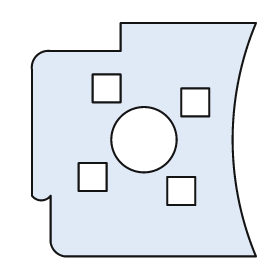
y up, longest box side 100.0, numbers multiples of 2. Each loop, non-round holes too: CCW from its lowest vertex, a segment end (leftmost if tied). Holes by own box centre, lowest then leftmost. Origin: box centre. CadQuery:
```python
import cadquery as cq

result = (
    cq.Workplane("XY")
    .moveTo(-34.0, -50.0)
    .lineTo(48.0, -50.0)
    .threePointArc((38.0, 0.0), (48.0, 50.0))
    .lineTo(-10.0, 50.0)
    .lineTo(-10.0, 38.0)
    .lineTo(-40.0, 38.0)
    .threePointArc((-46.0, 36.0), (-48.0, 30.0))
    .lineTo(-48.0, -24.0)
    .threePointArc((-44.0, -26.0), (-40.0, -24.0))
    .lineTo(-40.0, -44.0)
    .threePointArc((-38.0, -48.0), (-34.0, -50.0))
    .close()
    .moveTo(10.0, -28.0)
    .lineTo(22.0, -28.0)
    .lineTo(22.0, -16.0)
    .lineTo(10.0, -16.0)
    .close()
    .moveTo(-28.0, -22.0)
    .lineTo(-16.0, -22.0)
    .lineTo(-16.0, -10.0)
    .lineTo(-28.0, -10.0)
    .close()
    .moveTo(0.0, 0.0)
    .circle(14.0)
    .moveTo(16.0, 10.0)
    .lineTo(28.0, 10.0)
    .lineTo(28.0, 22.0)
    .lineTo(16.0, 22.0)
    .close()
    .moveTo(-22.0, 16.0)
    .lineTo(-10.0, 16.0)
    .lineTo(-10.0, 28.0)
    .lineTo(-22.0, 28.0)
    .close()
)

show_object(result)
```